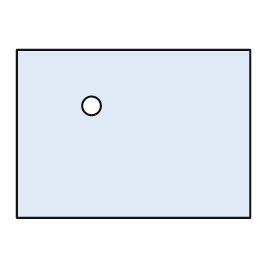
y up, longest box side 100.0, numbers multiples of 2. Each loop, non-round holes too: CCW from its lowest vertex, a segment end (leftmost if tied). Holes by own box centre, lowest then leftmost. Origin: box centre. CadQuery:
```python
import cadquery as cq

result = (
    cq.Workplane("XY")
    .moveTo(-50.0, -36.0)
    .lineTo(50.0, -36.0)
    .lineTo(50.0, 36.0)
    .lineTo(-50.0, 36.0)
    .close()
    .moveTo(-18.0, 12.0)
    .circle(4.0)
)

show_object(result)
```